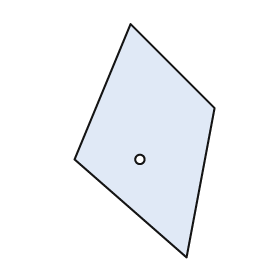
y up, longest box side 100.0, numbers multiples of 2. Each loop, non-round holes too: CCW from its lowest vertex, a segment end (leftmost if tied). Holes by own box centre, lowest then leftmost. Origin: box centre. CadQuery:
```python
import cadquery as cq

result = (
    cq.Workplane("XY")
    .moveTo(18.0, -50.0)
    .lineTo(30.0, 14.0)
    .lineTo(-6.0, 50.0)
    .lineTo(-30.0, -8.0)
    .close()
    .moveTo(-2.0, -8.0)
    .circle(2.0)
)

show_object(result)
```